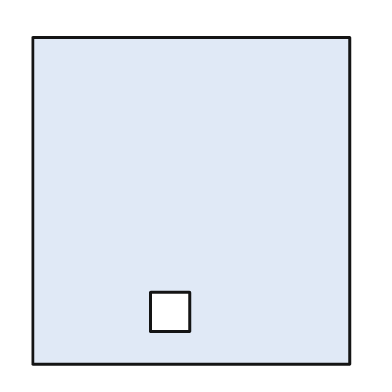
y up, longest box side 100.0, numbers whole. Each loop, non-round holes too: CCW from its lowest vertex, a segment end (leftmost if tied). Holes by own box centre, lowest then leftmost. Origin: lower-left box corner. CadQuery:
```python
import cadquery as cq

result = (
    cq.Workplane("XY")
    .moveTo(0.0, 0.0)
    .lineTo(97.0, 0.0)
    .lineTo(97.0, 100.0)
    .lineTo(0.0, 100.0)
    .close()
    .moveTo(36.0, 10.0)
    .lineTo(48.0, 10.0)
    .lineTo(48.0, 22.0)
    .lineTo(36.0, 22.0)
    .close()
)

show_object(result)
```